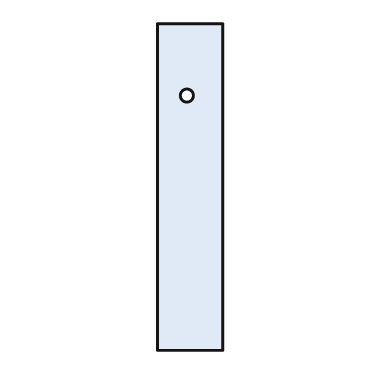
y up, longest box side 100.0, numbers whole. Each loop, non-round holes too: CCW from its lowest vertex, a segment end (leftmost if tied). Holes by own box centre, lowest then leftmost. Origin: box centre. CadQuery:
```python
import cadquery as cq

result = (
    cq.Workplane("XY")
    .moveTo(-10.0, -50.0)
    .lineTo(10.0, -50.0)
    .lineTo(10.0, 50.0)
    .lineTo(-10.0, 50.0)
    .close()
    .moveTo(-1.0, 28.0)
    .circle(2.0)
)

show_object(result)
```